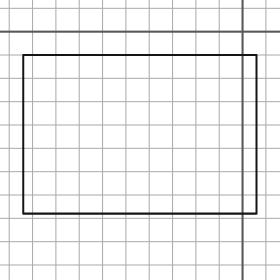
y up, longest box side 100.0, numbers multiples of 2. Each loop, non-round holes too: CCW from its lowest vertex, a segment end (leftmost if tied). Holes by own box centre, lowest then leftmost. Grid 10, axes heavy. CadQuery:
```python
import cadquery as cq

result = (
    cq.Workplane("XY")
    .moveTo(-94.0, -78.0)
    .lineTo(6.0, -78.0)
    .lineTo(6.0, -10.0)
    .lineTo(-94.0, -10.0)
    .close()
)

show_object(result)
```